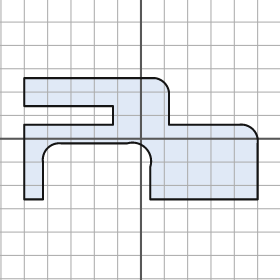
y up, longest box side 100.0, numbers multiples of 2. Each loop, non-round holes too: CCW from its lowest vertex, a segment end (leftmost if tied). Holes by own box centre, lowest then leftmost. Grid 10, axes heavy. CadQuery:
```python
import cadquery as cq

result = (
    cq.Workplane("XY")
    .moveTo(-50.0, -26.0)
    .lineTo(-42.0, -26.0)
    .lineTo(-42.0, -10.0)
    .threePointArc((-40.0, -4.0), (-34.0, -2.0))
    .lineTo(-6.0, -2.0)
    .threePointArc((2.0, -4.0), (4.0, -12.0))
    .lineTo(4.0, -26.0)
    .lineTo(50.0, -26.0)
    .lineTo(50.0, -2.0)
    .threePointArc((48.0, 4.0), (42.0, 6.0))
    .lineTo(12.0, 6.0)
    .lineTo(12.0, 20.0)
    .threePointArc((10.0, 24.0), (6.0, 26.0))
    .lineTo(-50.0, 26.0)
    .lineTo(-50.0, 14.0)
    .lineTo(-12.0, 14.0)
    .lineTo(-12.0, 6.0)
    .lineTo(-50.0, 6.0)
    .close()
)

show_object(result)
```